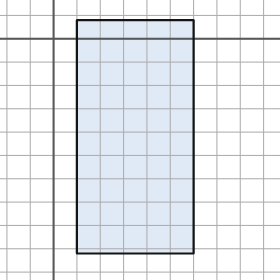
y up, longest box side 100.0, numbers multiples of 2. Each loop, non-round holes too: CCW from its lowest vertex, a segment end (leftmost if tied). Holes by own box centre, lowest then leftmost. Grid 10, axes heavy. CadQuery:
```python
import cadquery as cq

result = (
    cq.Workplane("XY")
    .moveTo(10.0, -92.0)
    .lineTo(60.0, -92.0)
    .lineTo(60.0, 8.0)
    .lineTo(10.0, 8.0)
    .close()
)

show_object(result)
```